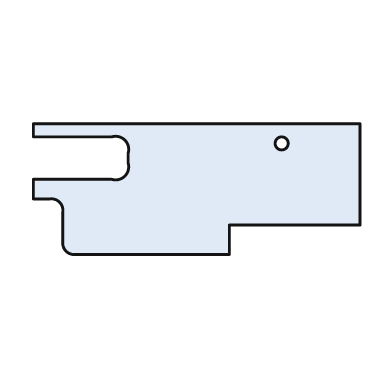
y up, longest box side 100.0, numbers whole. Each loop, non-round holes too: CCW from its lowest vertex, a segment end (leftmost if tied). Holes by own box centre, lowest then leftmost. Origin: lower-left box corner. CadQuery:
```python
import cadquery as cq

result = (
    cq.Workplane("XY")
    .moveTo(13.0, 0.0)
    .lineTo(60.0, 0.0)
    .lineTo(60.0, 9.0)
    .lineTo(100.0, 9.0)
    .lineTo(100.0, 40.0)
    .lineTo(0.0, 40.0)
    .lineTo(0.0, 36.0)
    .lineTo(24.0, 36.0)
    .threePointArc((28.0, 35.0), (29.0, 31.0))
    .lineTo(29.0, 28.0)
    .threePointArc((28.0, 24.0), (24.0, 23.0))
    .lineTo(0.0, 23.0)
    .lineTo(0.0, 17.0)
    .lineTo(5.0, 17.0)
    .threePointArc((8.0, 16.0), (9.0, 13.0))
    .lineTo(9.0, 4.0)
    .threePointArc((10.0, 1.0), (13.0, 0.0))
    .close()
    .moveTo(76.0, 34.0)
    .circle(2.0)
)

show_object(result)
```